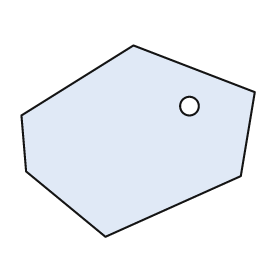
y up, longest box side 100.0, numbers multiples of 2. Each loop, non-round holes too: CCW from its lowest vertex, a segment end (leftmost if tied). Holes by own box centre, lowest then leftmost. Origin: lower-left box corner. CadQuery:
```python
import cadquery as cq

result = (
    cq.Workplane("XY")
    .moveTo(36.0, 0.0)
    .lineTo(94.0, 26.0)
    .lineTo(100.0, 62.0)
    .lineTo(48.0, 82.0)
    .lineTo(0.0, 52.0)
    .lineTo(2.0, 28.0)
    .close()
    .moveTo(72.0, 56.0)
    .circle(4.0)
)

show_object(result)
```